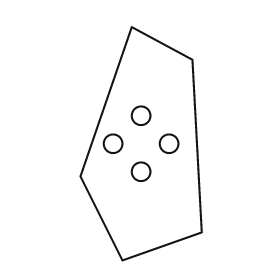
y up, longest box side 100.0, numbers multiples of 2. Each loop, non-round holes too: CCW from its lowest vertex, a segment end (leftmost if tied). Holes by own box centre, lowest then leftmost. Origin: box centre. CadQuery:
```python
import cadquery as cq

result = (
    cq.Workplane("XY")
    .moveTo(-8.0, -50.0)
    .lineTo(26.0, -38.0)
    .lineTo(22.0, 36.0)
    .lineTo(-4.0, 50.0)
    .lineTo(-26.0, -14.0)
    .close()
    .moveTo(0.0, -12.0)
    .circle(4.0)
    .moveTo(-12.0, 0.0)
    .circle(4.0)
    .moveTo(12.0, 0.0)
    .circle(4.0)
    .moveTo(0.0, 12.0)
    .circle(4.0)
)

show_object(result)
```